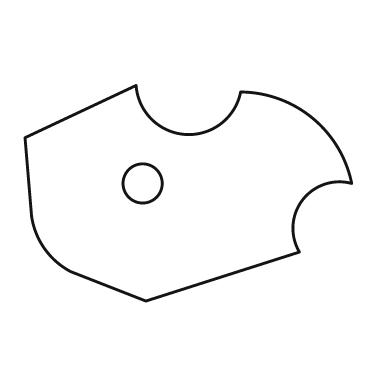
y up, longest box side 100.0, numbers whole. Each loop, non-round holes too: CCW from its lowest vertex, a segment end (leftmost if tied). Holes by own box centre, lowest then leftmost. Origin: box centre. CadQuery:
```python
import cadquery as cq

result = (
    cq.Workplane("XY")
    .moveTo(-13.0, -33.0)
    .lineTo(34.0, -18.0)
    .threePointArc((35.0, -2.0), (50.0, 3.0))
    .threePointArc((38.0, 23.0), (16.0, 31.0))
    .threePointArc((-1.0, 18.0), (-16.0, 33.0))
    .lineTo(-50.0, 17.0)
    .lineTo(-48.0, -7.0)
    .threePointArc((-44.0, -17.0), (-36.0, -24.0))
    .close()
    .moveTo(-14.0, 3.0)
    .circle(6.0)
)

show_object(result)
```